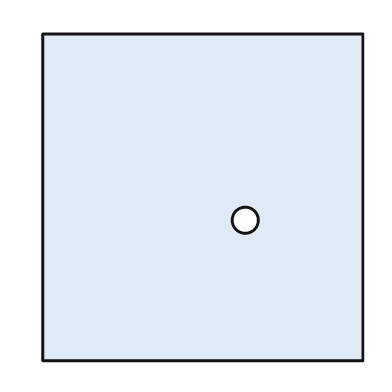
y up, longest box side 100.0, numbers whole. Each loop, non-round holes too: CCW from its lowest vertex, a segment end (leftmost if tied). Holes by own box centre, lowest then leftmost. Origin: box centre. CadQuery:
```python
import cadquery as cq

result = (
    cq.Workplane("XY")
    .moveTo(-49.0, -50.0)
    .lineTo(49.0, -50.0)
    .lineTo(49.0, 50.0)
    .lineTo(-49.0, 50.0)
    .close()
    .moveTo(13.0, -7.0)
    .circle(4.0)
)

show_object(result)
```